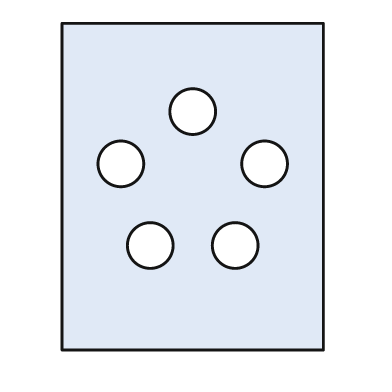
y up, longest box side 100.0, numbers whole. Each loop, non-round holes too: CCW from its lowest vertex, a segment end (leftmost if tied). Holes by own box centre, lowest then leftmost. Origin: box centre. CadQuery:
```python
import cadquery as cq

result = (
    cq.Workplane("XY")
    .moveTo(-40.0, -50.0)
    .lineTo(40.0, -50.0)
    .lineTo(40.0, 50.0)
    .lineTo(-40.0, 50.0)
    .close()
    .moveTo(-13.0, -18.0)
    .circle(7.0)
    .moveTo(13.0, -18.0)
    .circle(7.0)
    .moveTo(-22.0, 7.0)
    .circle(7.0)
    .moveTo(22.0, 7.0)
    .circle(7.0)
    .moveTo(0.0, 23.0)
    .circle(7.0)
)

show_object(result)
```